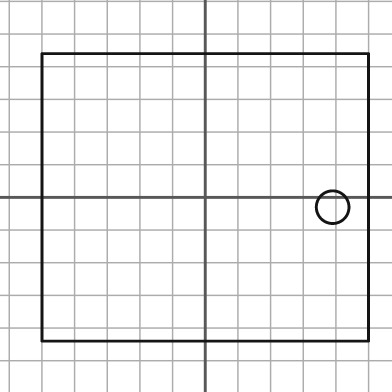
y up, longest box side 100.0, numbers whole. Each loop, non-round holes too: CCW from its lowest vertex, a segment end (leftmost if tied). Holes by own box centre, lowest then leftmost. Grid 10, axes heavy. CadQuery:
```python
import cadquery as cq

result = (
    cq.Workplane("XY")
    .moveTo(-50.0, -44.0)
    .lineTo(50.0, -44.0)
    .lineTo(50.0, 44.0)
    .lineTo(-50.0, 44.0)
    .close()
    .moveTo(39.0, -3.0)
    .circle(5.0)
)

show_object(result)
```